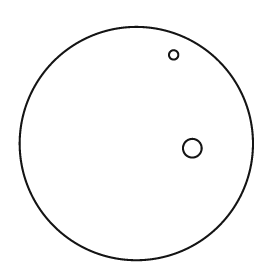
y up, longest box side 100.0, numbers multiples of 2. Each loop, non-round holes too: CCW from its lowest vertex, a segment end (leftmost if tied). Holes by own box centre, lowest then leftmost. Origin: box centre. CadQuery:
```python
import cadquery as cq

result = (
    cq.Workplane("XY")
    .moveTo(0.0, 0.0)
    .circle(50.0)
    .moveTo(24.0, -2.0)
    .circle(4.0)
    .moveTo(16.0, 38.0)
    .circle(2.0)
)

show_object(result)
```